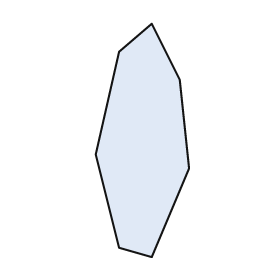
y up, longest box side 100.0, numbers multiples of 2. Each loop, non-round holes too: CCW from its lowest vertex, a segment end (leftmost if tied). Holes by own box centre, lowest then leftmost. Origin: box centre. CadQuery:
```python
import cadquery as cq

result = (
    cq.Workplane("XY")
    .moveTo(4.0, -50.0)
    .lineTo(20.0, -12.0)
    .lineTo(16.0, 26.0)
    .lineTo(4.0, 50.0)
    .lineTo(-10.0, 38.0)
    .lineTo(-20.0, -6.0)
    .lineTo(-10.0, -46.0)
    .close()
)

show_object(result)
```